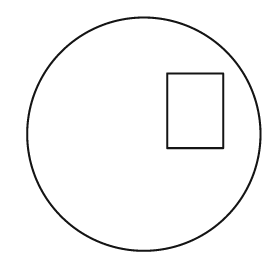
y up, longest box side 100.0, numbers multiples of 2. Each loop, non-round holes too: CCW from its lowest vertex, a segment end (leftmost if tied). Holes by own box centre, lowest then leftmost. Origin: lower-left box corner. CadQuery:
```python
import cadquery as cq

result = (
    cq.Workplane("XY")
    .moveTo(50.0, 50.0)
    .circle(50.0)
    .moveTo(60.0, 44.0)
    .lineTo(84.0, 44.0)
    .lineTo(84.0, 76.0)
    .lineTo(60.0, 76.0)
    .close()
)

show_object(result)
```